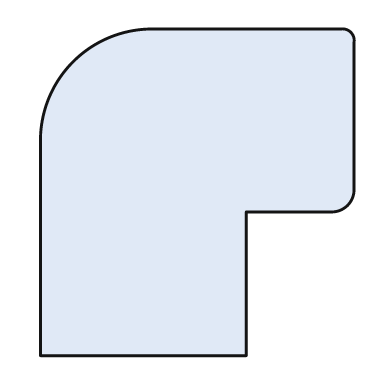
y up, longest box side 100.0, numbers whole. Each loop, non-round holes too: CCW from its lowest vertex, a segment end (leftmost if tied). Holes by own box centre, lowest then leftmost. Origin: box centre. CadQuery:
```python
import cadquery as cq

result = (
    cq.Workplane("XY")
    .moveTo(-48.0, -50.0)
    .lineTo(15.0, -50.0)
    .lineTo(15.0, -6.0)
    .lineTo(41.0, -6.0)
    .threePointArc((46.0, -4.0), (48.0, 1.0))
    .lineTo(48.0, 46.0)
    .threePointArc((47.0, 49.0), (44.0, 50.0))
    .lineTo(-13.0, 50.0)
    .threePointArc((-38.0, 40.0), (-48.0, 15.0))
    .close()
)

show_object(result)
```